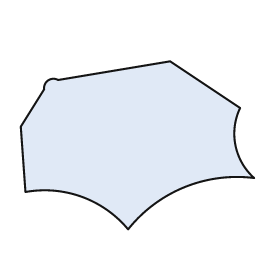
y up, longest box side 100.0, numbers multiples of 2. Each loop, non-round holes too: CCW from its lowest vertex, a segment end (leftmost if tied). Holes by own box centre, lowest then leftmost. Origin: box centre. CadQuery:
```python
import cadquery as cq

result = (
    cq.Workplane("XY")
    .moveTo(-4.0, -36.0)
    .threePointArc((20.0, -18.0), (50.0, -14.0))
    .threePointArc((42.0, 0.0), (44.0, 16.0))
    .lineTo(14.0, 36.0)
    .lineTo(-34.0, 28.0)
    .threePointArc((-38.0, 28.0), (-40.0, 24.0))
    .lineTo(-50.0, 8.0)
    .lineTo(-48.0, -20.0)
    .threePointArc((-24.0, -22.0), (-4.0, -36.0))
    .close()
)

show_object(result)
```